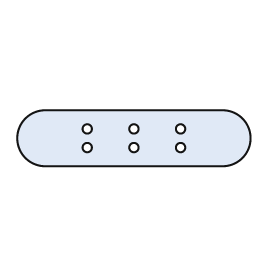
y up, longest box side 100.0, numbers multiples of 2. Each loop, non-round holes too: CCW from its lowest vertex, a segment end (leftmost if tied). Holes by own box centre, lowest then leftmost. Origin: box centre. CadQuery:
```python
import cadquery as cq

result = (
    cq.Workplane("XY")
    .moveTo(-38.0, -12.0)
    .lineTo(38.0, -12.0)
    .threePointArc((50.0, 0.0), (38.0, 12.0))
    .lineTo(-38.0, 12.0)
    .threePointArc((-50.0, 0.0), (-38.0, -12.0))
    .close()
    .moveTo(-20.0, -4.0)
    .circle(2.0)
    .moveTo(0.0, -4.0)
    .circle(2.0)
    .moveTo(20.0, -4.0)
    .circle(2.0)
    .moveTo(-20.0, 4.0)
    .circle(2.0)
    .moveTo(0.0, 4.0)
    .circle(2.0)
    .moveTo(20.0, 4.0)
    .circle(2.0)
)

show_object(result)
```